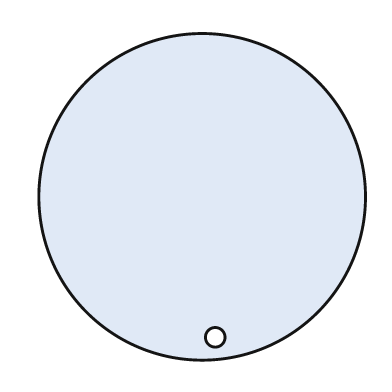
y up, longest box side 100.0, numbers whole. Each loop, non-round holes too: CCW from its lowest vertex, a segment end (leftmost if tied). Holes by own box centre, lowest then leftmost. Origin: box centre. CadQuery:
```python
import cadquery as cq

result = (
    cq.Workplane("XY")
    .moveTo(0.0, 0.0)
    .circle(50.0)
    .moveTo(4.0, -43.0)
    .circle(3.0)
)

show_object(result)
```